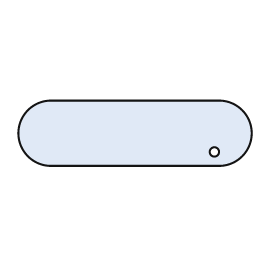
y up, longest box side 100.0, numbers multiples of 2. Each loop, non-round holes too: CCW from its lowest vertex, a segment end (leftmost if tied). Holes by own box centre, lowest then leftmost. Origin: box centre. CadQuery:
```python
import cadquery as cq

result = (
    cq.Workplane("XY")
    .moveTo(-36.0, -14.0)
    .lineTo(36.0, -14.0)
    .threePointArc((50.0, 0.0), (36.0, 14.0))
    .lineTo(-36.0, 14.0)
    .threePointArc((-50.0, 0.0), (-36.0, -14.0))
    .close()
    .moveTo(34.0, -8.0)
    .circle(2.0)
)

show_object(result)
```